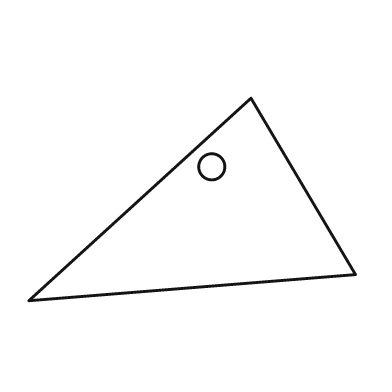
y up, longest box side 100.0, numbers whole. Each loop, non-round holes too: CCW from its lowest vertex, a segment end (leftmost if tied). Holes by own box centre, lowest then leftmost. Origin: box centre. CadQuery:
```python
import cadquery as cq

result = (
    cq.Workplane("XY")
    .moveTo(-50.0, -31.0)
    .lineTo(50.0, -23.0)
    .lineTo(18.0, 31.0)
    .close()
    .moveTo(6.0, 10.0)
    .circle(4.0)
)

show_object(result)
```